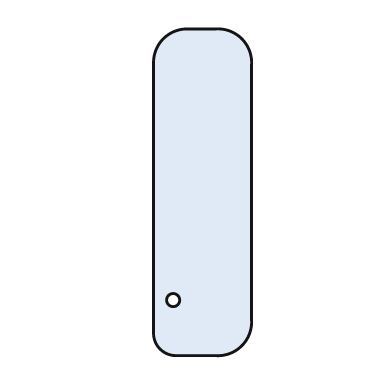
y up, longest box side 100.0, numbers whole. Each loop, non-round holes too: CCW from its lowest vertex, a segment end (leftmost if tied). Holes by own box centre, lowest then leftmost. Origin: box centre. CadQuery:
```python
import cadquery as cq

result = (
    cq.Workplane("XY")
    .moveTo(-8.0, -50.0)
    .lineTo(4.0, -50.0)
    .threePointArc((12.0, -47.0), (15.0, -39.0))
    .lineTo(15.0, 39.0)
    .threePointArc((12.0, 47.0), (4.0, 50.0))
    .lineTo(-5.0, 50.0)
    .threePointArc((-12.0, 47.0), (-15.0, 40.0))
    .lineTo(-15.0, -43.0)
    .threePointArc((-13.0, -48.0), (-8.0, -50.0))
    .close()
    .moveTo(-9.0, -33.0)
    .circle(2.0)
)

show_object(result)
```